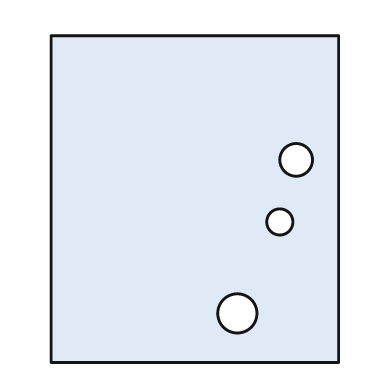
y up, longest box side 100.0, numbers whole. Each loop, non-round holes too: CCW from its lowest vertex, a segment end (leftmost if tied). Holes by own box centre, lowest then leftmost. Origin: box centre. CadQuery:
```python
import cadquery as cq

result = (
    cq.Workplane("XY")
    .moveTo(-44.0, -50.0)
    .lineTo(44.0, -50.0)
    .lineTo(44.0, 50.0)
    .lineTo(-44.0, 50.0)
    .close()
    .moveTo(13.0, -35.0)
    .circle(6.0)
    .moveTo(26.0, -7.0)
    .circle(4.0)
    .moveTo(31.0, 12.0)
    .circle(5.0)
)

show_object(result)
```